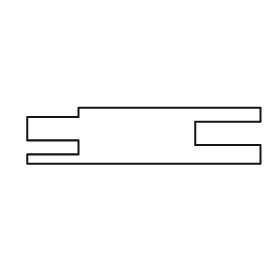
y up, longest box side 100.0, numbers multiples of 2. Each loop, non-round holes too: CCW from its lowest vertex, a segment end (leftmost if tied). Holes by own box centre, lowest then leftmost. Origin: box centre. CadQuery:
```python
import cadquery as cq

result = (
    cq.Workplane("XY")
    .moveTo(-50.0, -12.0)
    .lineTo(50.0, -12.0)
    .lineTo(50.0, -4.0)
    .lineTo(22.0, -4.0)
    .lineTo(22.0, 6.0)
    .lineTo(50.0, 6.0)
    .lineTo(50.0, 12.0)
    .lineTo(-28.0, 12.0)
    .lineTo(-28.0, 8.0)
    .lineTo(-50.0, 8.0)
    .lineTo(-50.0, -2.0)
    .lineTo(-28.0, -2.0)
    .lineTo(-28.0, -8.0)
    .lineTo(-50.0, -8.0)
    .close()
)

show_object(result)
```